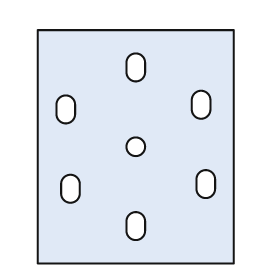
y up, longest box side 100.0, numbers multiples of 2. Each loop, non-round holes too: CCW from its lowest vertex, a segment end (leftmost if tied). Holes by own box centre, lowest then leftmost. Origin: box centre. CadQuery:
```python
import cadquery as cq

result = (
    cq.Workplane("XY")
    .moveTo(-42.0, -50.0)
    .lineTo(42.0, -50.0)
    .lineTo(42.0, 50.0)
    .lineTo(-42.0, 50.0)
    .close()
    .moveTo(-4.0, -36.0)
    .threePointArc((0.0, -40.0), (4.0, -36.0))
    .lineTo(4.0, -32.0)
    .threePointArc((0.0, -28.0), (-4.0, -32.0))
    .close()
    .moveTo(-32.0, -20.0)
    .threePointArc((-28.0, -24.0), (-24.0, -20.0))
    .lineTo(-24.0, -16.0)
    .threePointArc((-28.0, -12.0), (-32.0, -16.0))
    .close()
    .moveTo(26.0, -18.0)
    .threePointArc((30.0, -22.0), (34.0, -18.0))
    .lineTo(34.0, -14.0)
    .threePointArc((30.0, -10.0), (26.0, -14.0))
    .close()
    .moveTo(0.0, 0.0)
    .circle(4.0)
    .moveTo(-34.0, 14.0)
    .threePointArc((-30.0, 10.0), (-26.0, 14.0))
    .lineTo(-26.0, 18.0)
    .threePointArc((-30.0, 22.0), (-34.0, 18.0))
    .close()
    .moveTo(24.0, 16.0)
    .threePointArc((28.0, 12.0), (32.0, 16.0))
    .lineTo(32.0, 20.0)
    .threePointArc((28.0, 24.0), (24.0, 20.0))
    .close()
    .moveTo(-4.0, 32.0)
    .threePointArc((0.0, 28.0), (4.0, 32.0))
    .lineTo(4.0, 36.0)
    .threePointArc((0.0, 40.0), (-4.0, 36.0))
    .close()
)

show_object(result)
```